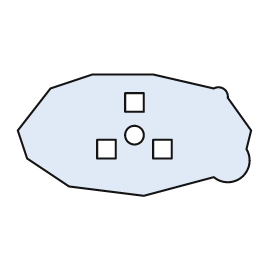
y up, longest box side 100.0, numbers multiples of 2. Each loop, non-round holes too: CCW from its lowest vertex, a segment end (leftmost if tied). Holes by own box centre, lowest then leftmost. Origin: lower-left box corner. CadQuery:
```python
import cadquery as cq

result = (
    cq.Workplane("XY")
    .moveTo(54.0, 0.0)
    .lineTo(84.0, 8.0)
    .threePointArc((96.0, 8.0), (98.0, 20.0))
    .lineTo(100.0, 28.0)
    .lineTo(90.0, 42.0)
    .threePointArc((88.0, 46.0), (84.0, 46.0))
    .lineTo(58.0, 52.0)
    .lineTo(32.0, 52.0)
    .lineTo(14.0, 46.0)
    .lineTo(0.0, 28.0)
    .lineTo(4.0, 16.0)
    .lineTo(22.0, 4.0)
    .close()
    .moveTo(34.0, 16.0)
    .lineTo(42.0, 16.0)
    .lineTo(42.0, 24.0)
    .lineTo(34.0, 24.0)
    .close()
    .moveTo(58.0, 16.0)
    .lineTo(66.0, 16.0)
    .lineTo(66.0, 24.0)
    .lineTo(58.0, 24.0)
    .close()
    .moveTo(50.0, 26.0)
    .circle(4.0)
    .moveTo(46.0, 36.0)
    .lineTo(54.0, 36.0)
    .lineTo(54.0, 44.0)
    .lineTo(46.0, 44.0)
    .close()
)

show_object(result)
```